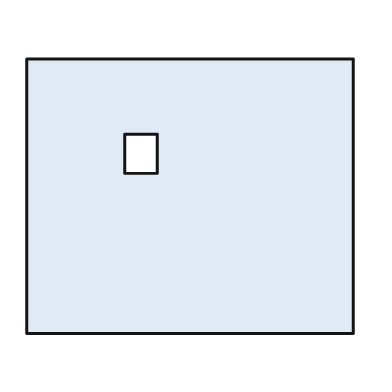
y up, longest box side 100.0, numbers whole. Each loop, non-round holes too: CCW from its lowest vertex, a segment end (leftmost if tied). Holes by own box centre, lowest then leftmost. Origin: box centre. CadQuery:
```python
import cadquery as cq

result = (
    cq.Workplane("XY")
    .moveTo(-50.0, -42.0)
    .lineTo(50.0, -42.0)
    .lineTo(50.0, 42.0)
    .lineTo(-50.0, 42.0)
    .close()
    .moveTo(-20.0, 7.0)
    .lineTo(-10.0, 7.0)
    .lineTo(-10.0, 19.0)
    .lineTo(-20.0, 19.0)
    .close()
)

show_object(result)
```